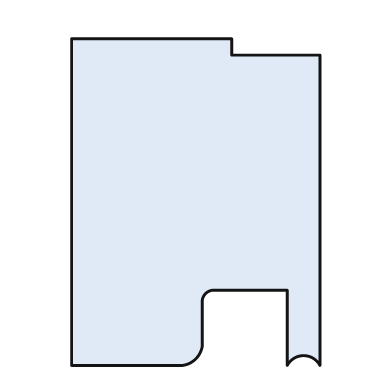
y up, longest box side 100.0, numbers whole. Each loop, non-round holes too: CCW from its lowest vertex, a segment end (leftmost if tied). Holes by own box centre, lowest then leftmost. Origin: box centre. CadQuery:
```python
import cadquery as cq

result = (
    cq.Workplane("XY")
    .moveTo(-38.0, -50.0)
    .lineTo(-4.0, -50.0)
    .threePointArc((0.0, -48.0), (2.0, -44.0))
    .lineTo(2.0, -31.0)
    .threePointArc((3.0, -28.0), (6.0, -27.0))
    .lineTo(28.0, -27.0)
    .lineTo(28.0, -50.0)
    .threePointArc((33.0, -47.0), (38.0, -50.0))
    .lineTo(38.0, 45.0)
    .lineTo(11.0, 45.0)
    .lineTo(11.0, 50.0)
    .lineTo(-38.0, 50.0)
    .close()
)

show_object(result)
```